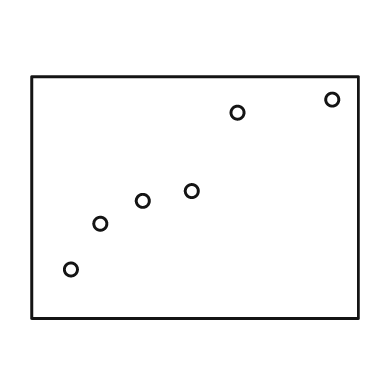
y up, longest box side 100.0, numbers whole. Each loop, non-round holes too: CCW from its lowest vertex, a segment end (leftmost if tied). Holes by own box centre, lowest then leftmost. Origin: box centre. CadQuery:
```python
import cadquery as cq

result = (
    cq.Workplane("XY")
    .moveTo(-50.0, -37.0)
    .lineTo(50.0, -37.0)
    .lineTo(50.0, 37.0)
    .lineTo(-50.0, 37.0)
    .close()
    .moveTo(-38.0, -22.0)
    .circle(2.0)
    .moveTo(-29.0, -8.0)
    .circle(2.0)
    .moveTo(-16.0, -1.0)
    .circle(2.0)
    .moveTo(-1.0, 2.0)
    .circle(2.0)
    .moveTo(13.0, 26.0)
    .circle(2.0)
    .moveTo(42.0, 30.0)
    .circle(2.0)
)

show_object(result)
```